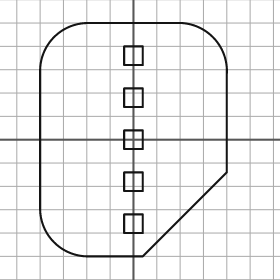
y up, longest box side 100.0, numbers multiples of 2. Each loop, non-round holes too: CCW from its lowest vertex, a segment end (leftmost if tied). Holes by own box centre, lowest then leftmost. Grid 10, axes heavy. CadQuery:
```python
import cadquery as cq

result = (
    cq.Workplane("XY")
    .moveTo(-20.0, -50.0)
    .lineTo(4.0, -50.0)
    .lineTo(40.0, -14.0)
    .lineTo(40.0, 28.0)
    .threePointArc((34.0, 44.0), (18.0, 50.0))
    .lineTo(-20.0, 50.0)
    .threePointArc((-34.0, 44.0), (-40.0, 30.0))
    .lineTo(-40.0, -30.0)
    .threePointArc((-34.0, -44.0), (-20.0, -50.0))
    .close()
    .moveTo(-4.0, -40.0)
    .lineTo(4.0, -40.0)
    .lineTo(4.0, -32.0)
    .lineTo(-4.0, -32.0)
    .close()
    .moveTo(-4.0, -22.0)
    .lineTo(4.0, -22.0)
    .lineTo(4.0, -14.0)
    .lineTo(-4.0, -14.0)
    .close()
    .moveTo(-4.0, -4.0)
    .lineTo(4.0, -4.0)
    .lineTo(4.0, 4.0)
    .lineTo(-4.0, 4.0)
    .close()
    .moveTo(-4.0, 14.0)
    .lineTo(4.0, 14.0)
    .lineTo(4.0, 22.0)
    .lineTo(-4.0, 22.0)
    .close()
    .moveTo(-4.0, 32.0)
    .lineTo(4.0, 32.0)
    .lineTo(4.0, 40.0)
    .lineTo(-4.0, 40.0)
    .close()
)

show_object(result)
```